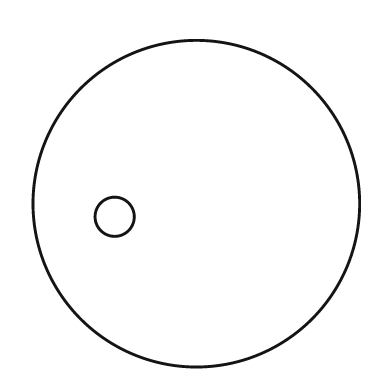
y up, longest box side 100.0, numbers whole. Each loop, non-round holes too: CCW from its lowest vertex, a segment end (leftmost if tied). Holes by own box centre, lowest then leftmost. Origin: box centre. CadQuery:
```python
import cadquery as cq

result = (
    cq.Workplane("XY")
    .moveTo(0.0, 0.0)
    .circle(50.0)
    .moveTo(-25.0, -4.0)
    .circle(6.0)
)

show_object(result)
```